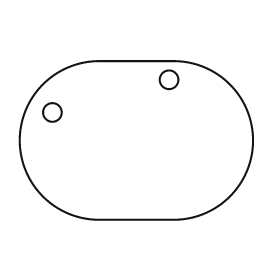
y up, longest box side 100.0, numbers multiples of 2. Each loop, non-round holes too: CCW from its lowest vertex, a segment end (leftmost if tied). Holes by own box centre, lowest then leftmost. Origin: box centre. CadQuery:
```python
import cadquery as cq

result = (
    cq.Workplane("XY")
    .moveTo(-16.0, -34.0)
    .lineTo(16.0, -34.0)
    .threePointArc((50.0, 0.0), (16.0, 34.0))
    .lineTo(-16.0, 34.0)
    .threePointArc((-50.0, 0.0), (-16.0, -34.0))
    .close()
    .moveTo(-36.0, 12.0)
    .circle(4.0)
    .moveTo(14.0, 26.0)
    .circle(4.0)
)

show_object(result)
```